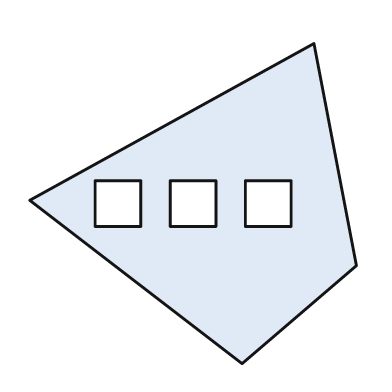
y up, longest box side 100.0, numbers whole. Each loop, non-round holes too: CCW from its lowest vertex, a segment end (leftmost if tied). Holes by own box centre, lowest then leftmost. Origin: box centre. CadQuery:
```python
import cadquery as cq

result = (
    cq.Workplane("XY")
    .moveTo(15.0, -49.0)
    .lineTo(50.0, -19.0)
    .lineTo(37.0, 49.0)
    .lineTo(-50.0, 1.0)
    .close()
    .moveTo(-30.0, -7.0)
    .lineTo(-16.0, -7.0)
    .lineTo(-16.0, 7.0)
    .lineTo(-30.0, 7.0)
    .close()
    .moveTo(-7.0, -7.0)
    .lineTo(7.0, -7.0)
    .lineTo(7.0, 7.0)
    .lineTo(-7.0, 7.0)
    .close()
    .moveTo(16.0, -7.0)
    .lineTo(30.0, -7.0)
    .lineTo(30.0, 7.0)
    .lineTo(16.0, 7.0)
    .close()
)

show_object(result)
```